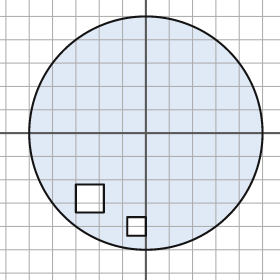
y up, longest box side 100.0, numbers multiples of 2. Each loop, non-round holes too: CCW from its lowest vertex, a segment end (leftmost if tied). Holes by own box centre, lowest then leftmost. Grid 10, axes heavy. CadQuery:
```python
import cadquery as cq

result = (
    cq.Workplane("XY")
    .moveTo(0.0, 0.0)
    .circle(50.0)
    .moveTo(-8.0, -44.0)
    .lineTo(0.0, -44.0)
    .lineTo(0.0, -36.0)
    .lineTo(-8.0, -36.0)
    .close()
    .moveTo(-30.0, -34.0)
    .lineTo(-18.0, -34.0)
    .lineTo(-18.0, -22.0)
    .lineTo(-30.0, -22.0)
    .close()
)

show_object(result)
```